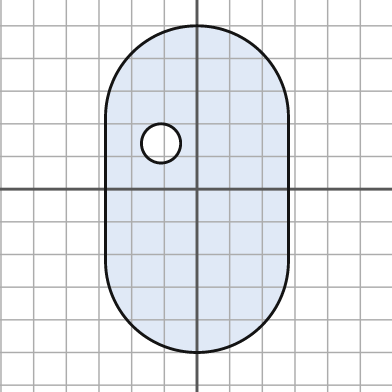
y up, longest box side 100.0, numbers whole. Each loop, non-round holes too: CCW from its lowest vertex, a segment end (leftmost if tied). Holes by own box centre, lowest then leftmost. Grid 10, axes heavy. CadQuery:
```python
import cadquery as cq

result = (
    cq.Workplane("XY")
    .moveTo(-28.0, -22.0)
    .threePointArc((0.0, -50.0), (28.0, -22.0))
    .lineTo(28.0, 22.0)
    .threePointArc((0.0, 50.0), (-28.0, 22.0))
    .close()
    .moveTo(-11.0, 14.0)
    .circle(6.0)
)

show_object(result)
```